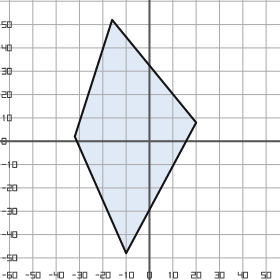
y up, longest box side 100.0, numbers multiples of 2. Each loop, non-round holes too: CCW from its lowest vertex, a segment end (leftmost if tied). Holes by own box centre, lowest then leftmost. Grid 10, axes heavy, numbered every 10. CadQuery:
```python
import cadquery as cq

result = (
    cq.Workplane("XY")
    .moveTo(-10.0, -48.0)
    .lineTo(20.0, 8.0)
    .lineTo(-16.0, 52.0)
    .lineTo(-32.0, 2.0)
    .close()
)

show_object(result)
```